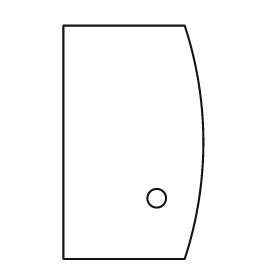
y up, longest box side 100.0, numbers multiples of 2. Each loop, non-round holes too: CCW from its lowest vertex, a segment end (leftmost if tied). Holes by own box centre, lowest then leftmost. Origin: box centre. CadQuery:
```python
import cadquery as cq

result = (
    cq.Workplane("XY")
    .moveTo(-30.0, -50.0)
    .lineTo(22.0, -50.0)
    .threePointArc((30.0, 0.0), (22.0, 50.0))
    .lineTo(-30.0, 50.0)
    .close()
    .moveTo(10.0, -24.0)
    .circle(4.0)
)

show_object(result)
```